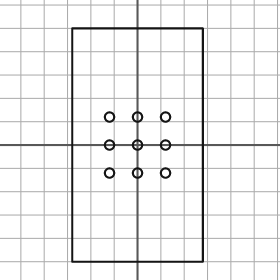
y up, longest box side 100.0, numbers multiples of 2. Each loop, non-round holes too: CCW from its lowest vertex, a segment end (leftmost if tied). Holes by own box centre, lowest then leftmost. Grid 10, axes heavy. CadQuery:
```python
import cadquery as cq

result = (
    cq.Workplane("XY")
    .moveTo(-28.0, -50.0)
    .lineTo(28.0, -50.0)
    .lineTo(28.0, 50.0)
    .lineTo(-28.0, 50.0)
    .close()
    .moveTo(-12.0, -12.0)
    .circle(2.0)
    .moveTo(0.0, -12.0)
    .circle(2.0)
    .moveTo(12.0, -12.0)
    .circle(2.0)
    .moveTo(-12.0, 0.0)
    .circle(2.0)
    .moveTo(0.0, 0.0)
    .circle(2.0)
    .moveTo(12.0, 0.0)
    .circle(2.0)
    .moveTo(-12.0, 12.0)
    .circle(2.0)
    .moveTo(0.0, 12.0)
    .circle(2.0)
    .moveTo(12.0, 12.0)
    .circle(2.0)
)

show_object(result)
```